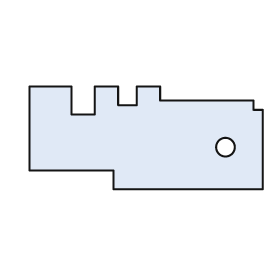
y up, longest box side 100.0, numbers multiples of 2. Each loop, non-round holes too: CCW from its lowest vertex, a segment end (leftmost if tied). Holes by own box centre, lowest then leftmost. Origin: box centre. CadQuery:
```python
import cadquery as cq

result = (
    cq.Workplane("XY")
    .moveTo(-14.0, -22.0)
    .lineTo(50.0, -22.0)
    .lineTo(50.0, 12.0)
    .lineTo(46.0, 12.0)
    .lineTo(46.0, 16.0)
    .lineTo(6.0, 16.0)
    .lineTo(6.0, 22.0)
    .lineTo(-4.0, 22.0)
    .lineTo(-4.0, 14.0)
    .lineTo(-12.0, 14.0)
    .lineTo(-12.0, 22.0)
    .lineTo(-22.0, 22.0)
    .lineTo(-22.0, 10.0)
    .lineTo(-32.0, 10.0)
    .lineTo(-32.0, 22.0)
    .lineTo(-50.0, 22.0)
    .lineTo(-50.0, -14.0)
    .lineTo(-14.0, -14.0)
    .close()
    .moveTo(34.0, -4.0)
    .circle(4.0)
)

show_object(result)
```